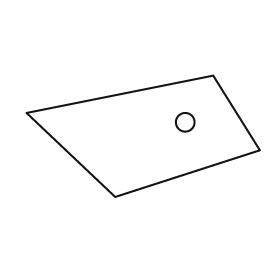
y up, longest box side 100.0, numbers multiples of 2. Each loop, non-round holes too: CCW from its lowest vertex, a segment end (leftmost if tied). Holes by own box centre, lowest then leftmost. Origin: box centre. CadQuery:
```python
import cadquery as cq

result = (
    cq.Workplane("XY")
    .moveTo(-12.0, -26.0)
    .lineTo(50.0, -6.0)
    .lineTo(30.0, 26.0)
    .lineTo(-50.0, 10.0)
    .close()
    .moveTo(18.0, 6.0)
    .circle(4.0)
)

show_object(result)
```